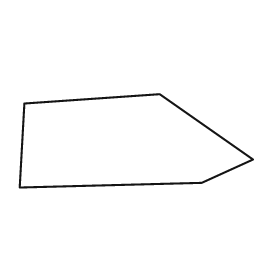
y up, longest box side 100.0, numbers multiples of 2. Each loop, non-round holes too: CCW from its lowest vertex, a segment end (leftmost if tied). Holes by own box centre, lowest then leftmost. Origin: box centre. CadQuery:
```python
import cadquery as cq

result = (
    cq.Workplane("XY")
    .moveTo(-50.0, -20.0)
    .lineTo(28.0, -18.0)
    .lineTo(50.0, -8.0)
    .lineTo(10.0, 20.0)
    .lineTo(-48.0, 16.0)
    .close()
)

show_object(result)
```